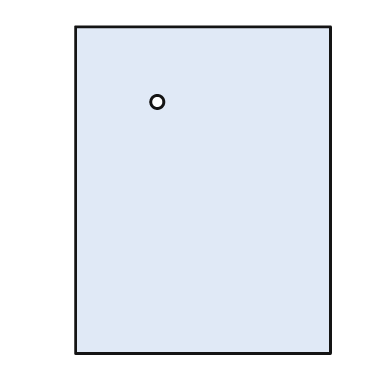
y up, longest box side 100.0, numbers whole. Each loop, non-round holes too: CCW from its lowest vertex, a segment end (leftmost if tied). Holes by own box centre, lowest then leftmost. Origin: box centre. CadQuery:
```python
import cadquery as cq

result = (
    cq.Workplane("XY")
    .moveTo(-39.0, -50.0)
    .lineTo(39.0, -50.0)
    .lineTo(39.0, 50.0)
    .lineTo(-39.0, 50.0)
    .close()
    .moveTo(-14.0, 27.0)
    .circle(2.0)
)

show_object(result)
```